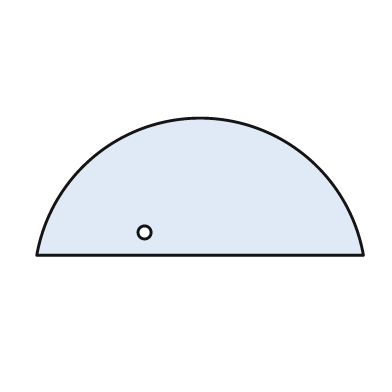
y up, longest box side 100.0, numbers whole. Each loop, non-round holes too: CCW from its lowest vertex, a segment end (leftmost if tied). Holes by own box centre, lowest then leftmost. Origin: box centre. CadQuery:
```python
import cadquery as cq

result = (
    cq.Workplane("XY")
    .moveTo(-50.0, -21.0)
    .lineTo(50.0, -21.0)
    .threePointArc((0.0, 21.0), (-50.0, -21.0))
    .close()
    .moveTo(-17.0, -14.0)
    .circle(2.0)
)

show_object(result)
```